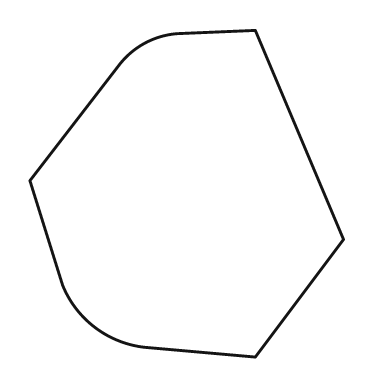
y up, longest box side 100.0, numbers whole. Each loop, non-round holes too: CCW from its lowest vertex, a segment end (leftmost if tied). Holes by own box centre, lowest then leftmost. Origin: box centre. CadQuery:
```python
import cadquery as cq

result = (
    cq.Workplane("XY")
    .moveTo(21.0, -50.0)
    .lineTo(48.0, -14.0)
    .lineTo(21.0, 50.0)
    .lineTo(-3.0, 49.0)
    .threePointArc((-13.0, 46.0), (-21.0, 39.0))
    .lineTo(-48.0, 4.0)
    .lineTo(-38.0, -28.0)
    .threePointArc((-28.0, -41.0), (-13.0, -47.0))
    .close()
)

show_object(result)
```